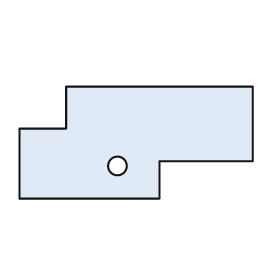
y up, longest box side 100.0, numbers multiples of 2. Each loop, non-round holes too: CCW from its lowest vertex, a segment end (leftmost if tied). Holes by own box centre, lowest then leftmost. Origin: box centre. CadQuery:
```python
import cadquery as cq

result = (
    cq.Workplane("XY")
    .moveTo(-50.0, -24.0)
    .lineTo(10.0, -24.0)
    .lineTo(10.0, -8.0)
    .lineTo(50.0, -8.0)
    .lineTo(50.0, 24.0)
    .lineTo(-30.0, 24.0)
    .lineTo(-30.0, 6.0)
    .lineTo(-50.0, 6.0)
    .close()
    .moveTo(-8.0, -10.0)
    .circle(4.0)
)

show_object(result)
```